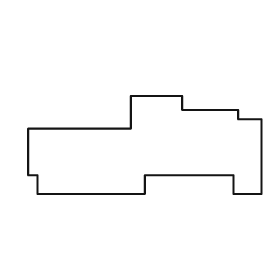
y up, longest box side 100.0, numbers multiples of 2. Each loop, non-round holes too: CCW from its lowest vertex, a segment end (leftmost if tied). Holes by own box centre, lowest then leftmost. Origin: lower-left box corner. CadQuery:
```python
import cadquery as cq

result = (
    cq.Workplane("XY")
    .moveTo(4.0, 0.0)
    .lineTo(50.0, 0.0)
    .lineTo(50.0, 8.0)
    .lineTo(88.0, 8.0)
    .lineTo(88.0, 0.0)
    .lineTo(100.0, 0.0)
    .lineTo(100.0, 32.0)
    .lineTo(90.0, 32.0)
    .lineTo(90.0, 36.0)
    .lineTo(66.0, 36.0)
    .lineTo(66.0, 42.0)
    .lineTo(44.0, 42.0)
    .lineTo(44.0, 28.0)
    .lineTo(0.0, 28.0)
    .lineTo(0.0, 8.0)
    .lineTo(4.0, 8.0)
    .close()
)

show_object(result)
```